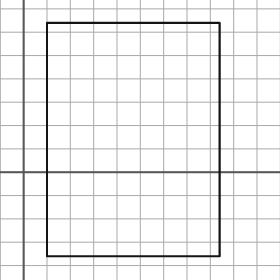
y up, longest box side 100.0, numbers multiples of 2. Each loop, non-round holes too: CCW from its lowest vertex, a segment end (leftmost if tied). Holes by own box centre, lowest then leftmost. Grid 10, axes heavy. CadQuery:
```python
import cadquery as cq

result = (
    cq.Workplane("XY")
    .moveTo(10.0, -36.0)
    .lineTo(84.0, -36.0)
    .lineTo(84.0, 64.0)
    .lineTo(10.0, 64.0)
    .close()
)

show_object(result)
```